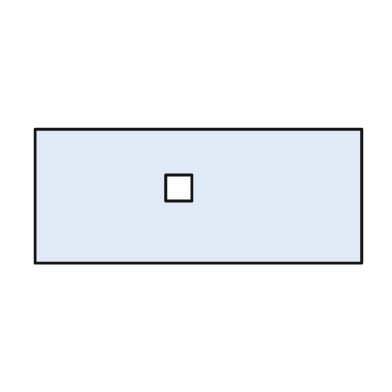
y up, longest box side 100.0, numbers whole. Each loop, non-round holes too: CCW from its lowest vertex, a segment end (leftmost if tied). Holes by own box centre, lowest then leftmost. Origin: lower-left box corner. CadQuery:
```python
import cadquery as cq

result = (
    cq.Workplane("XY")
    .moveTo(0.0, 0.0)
    .lineTo(100.0, 0.0)
    .lineTo(100.0, 41.0)
    .lineTo(0.0, 41.0)
    .close()
    .moveTo(40.0, 19.0)
    .lineTo(48.0, 19.0)
    .lineTo(48.0, 27.0)
    .lineTo(40.0, 27.0)
    .close()
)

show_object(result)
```